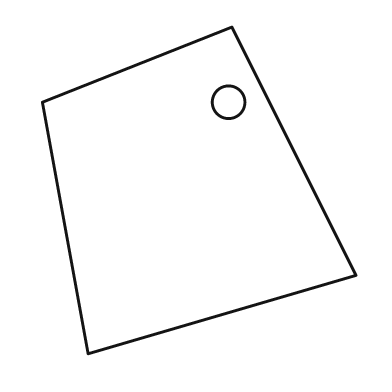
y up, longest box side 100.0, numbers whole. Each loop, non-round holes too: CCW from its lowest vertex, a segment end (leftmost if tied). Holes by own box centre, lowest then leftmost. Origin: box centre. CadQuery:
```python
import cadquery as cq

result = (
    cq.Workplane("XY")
    .moveTo(-34.0, -50.0)
    .lineTo(48.0, -26.0)
    .lineTo(10.0, 50.0)
    .lineTo(-48.0, 27.0)
    .close()
    .moveTo(9.0, 27.0)
    .circle(5.0)
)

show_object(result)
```